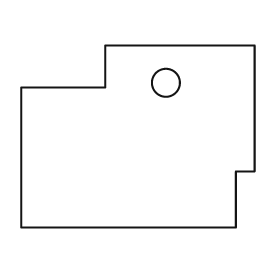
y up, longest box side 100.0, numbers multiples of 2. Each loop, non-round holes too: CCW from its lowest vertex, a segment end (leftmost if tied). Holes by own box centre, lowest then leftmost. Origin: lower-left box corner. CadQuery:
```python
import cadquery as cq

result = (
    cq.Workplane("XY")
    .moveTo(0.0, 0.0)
    .lineTo(92.0, 0.0)
    .lineTo(92.0, 24.0)
    .lineTo(100.0, 24.0)
    .lineTo(100.0, 78.0)
    .lineTo(36.0, 78.0)
    .lineTo(36.0, 60.0)
    .lineTo(0.0, 60.0)
    .close()
    .moveTo(62.0, 62.0)
    .circle(6.0)
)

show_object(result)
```